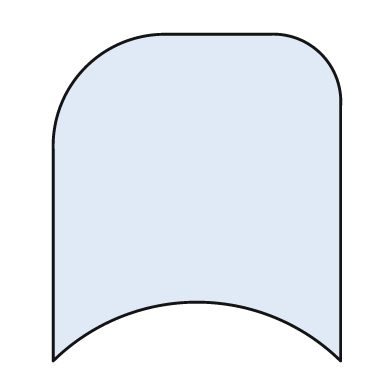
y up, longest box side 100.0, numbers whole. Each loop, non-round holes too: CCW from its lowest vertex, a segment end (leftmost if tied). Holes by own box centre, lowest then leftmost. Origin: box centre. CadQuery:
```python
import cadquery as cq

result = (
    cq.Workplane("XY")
    .moveTo(-44.0, -50.0)
    .threePointArc((0.0, -32.0), (44.0, -50.0))
    .lineTo(44.0, 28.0)
    .threePointArc((38.0, 44.0), (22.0, 50.0))
    .lineTo(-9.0, 50.0)
    .threePointArc((-34.0, 40.0), (-44.0, 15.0))
    .close()
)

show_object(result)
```